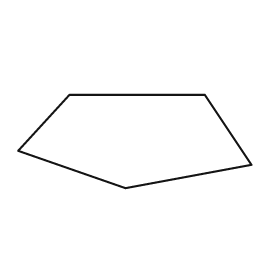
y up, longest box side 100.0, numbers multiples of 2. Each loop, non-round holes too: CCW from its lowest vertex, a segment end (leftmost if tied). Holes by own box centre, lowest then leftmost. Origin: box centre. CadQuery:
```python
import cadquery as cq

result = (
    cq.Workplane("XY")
    .moveTo(-4.0, -20.0)
    .lineTo(50.0, -10.0)
    .lineTo(30.0, 20.0)
    .lineTo(-28.0, 20.0)
    .lineTo(-50.0, -4.0)
    .close()
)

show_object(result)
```